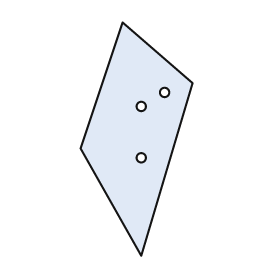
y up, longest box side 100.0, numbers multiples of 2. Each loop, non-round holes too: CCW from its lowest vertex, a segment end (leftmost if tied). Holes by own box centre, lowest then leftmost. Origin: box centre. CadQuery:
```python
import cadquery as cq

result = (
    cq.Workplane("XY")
    .moveTo(2.0, -50.0)
    .lineTo(24.0, 24.0)
    .lineTo(-6.0, 50.0)
    .lineTo(-24.0, -4.0)
    .close()
    .moveTo(2.0, -8.0)
    .circle(2.0)
    .moveTo(2.0, 14.0)
    .circle(2.0)
    .moveTo(12.0, 20.0)
    .circle(2.0)
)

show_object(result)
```